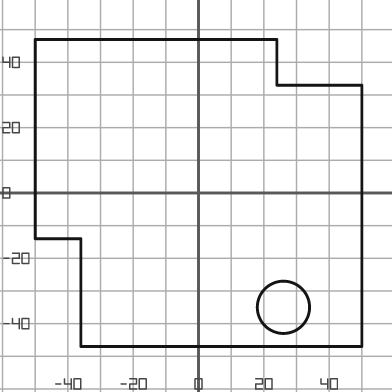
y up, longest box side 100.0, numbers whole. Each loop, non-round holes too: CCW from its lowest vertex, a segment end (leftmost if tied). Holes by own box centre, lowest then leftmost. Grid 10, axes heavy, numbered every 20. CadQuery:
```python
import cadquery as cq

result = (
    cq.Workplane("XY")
    .moveTo(-36.0, -47.0)
    .lineTo(50.0, -47.0)
    .lineTo(50.0, 33.0)
    .lineTo(24.0, 33.0)
    .lineTo(24.0, 47.0)
    .lineTo(-50.0, 47.0)
    .lineTo(-50.0, -14.0)
    .lineTo(-36.0, -14.0)
    .close()
    .moveTo(26.0, -35.0)
    .circle(8.0)
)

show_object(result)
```